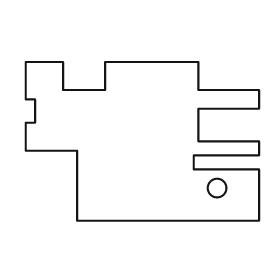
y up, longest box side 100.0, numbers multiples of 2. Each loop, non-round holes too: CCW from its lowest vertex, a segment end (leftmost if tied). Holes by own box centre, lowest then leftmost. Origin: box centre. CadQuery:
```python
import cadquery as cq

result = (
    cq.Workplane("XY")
    .moveTo(-28.0, -34.0)
    .lineTo(50.0, -34.0)
    .lineTo(50.0, -12.0)
    .lineTo(22.0, -12.0)
    .lineTo(22.0, -6.0)
    .lineTo(50.0, -6.0)
    .lineTo(50.0, 0.0)
    .lineTo(24.0, 0.0)
    .lineTo(24.0, 14.0)
    .lineTo(50.0, 14.0)
    .lineTo(50.0, 22.0)
    .lineTo(24.0, 22.0)
    .lineTo(24.0, 34.0)
    .lineTo(-16.0, 34.0)
    .lineTo(-16.0, 22.0)
    .lineTo(-34.0, 22.0)
    .lineTo(-34.0, 34.0)
    .lineTo(-50.0, 34.0)
    .lineTo(-50.0, 18.0)
    .lineTo(-46.0, 18.0)
    .lineTo(-46.0, 8.0)
    .lineTo(-50.0, 8.0)
    .lineTo(-50.0, -4.0)
    .lineTo(-28.0, -4.0)
    .close()
    .moveTo(32.0, -20.0)
    .circle(4.0)
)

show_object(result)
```